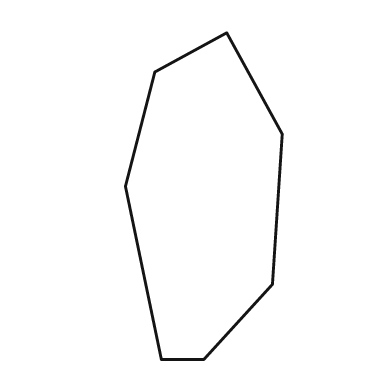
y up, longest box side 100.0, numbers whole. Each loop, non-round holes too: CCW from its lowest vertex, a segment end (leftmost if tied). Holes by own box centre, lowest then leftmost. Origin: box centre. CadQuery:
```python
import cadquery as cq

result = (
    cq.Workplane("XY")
    .moveTo(-13.0, -50.0)
    .lineTo(0.0, -50.0)
    .lineTo(21.0, -27.0)
    .lineTo(24.0, 19.0)
    .lineTo(7.0, 50.0)
    .lineTo(-15.0, 38.0)
    .lineTo(-24.0, 3.0)
    .close()
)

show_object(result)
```